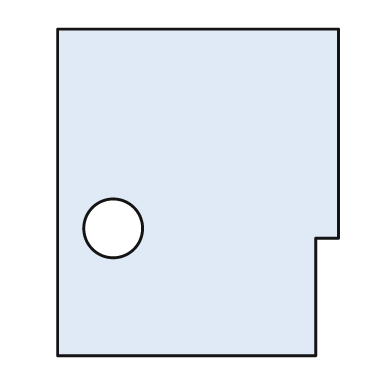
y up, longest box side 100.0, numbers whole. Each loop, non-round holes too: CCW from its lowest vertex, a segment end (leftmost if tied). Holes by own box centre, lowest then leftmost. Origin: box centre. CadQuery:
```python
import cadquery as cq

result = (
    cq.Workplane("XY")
    .moveTo(-43.0, -50.0)
    .lineTo(36.0, -50.0)
    .lineTo(36.0, -14.0)
    .lineTo(43.0, -14.0)
    .lineTo(43.0, 50.0)
    .lineTo(-43.0, 50.0)
    .close()
    .moveTo(-26.0, -11.0)
    .circle(9.0)
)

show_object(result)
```